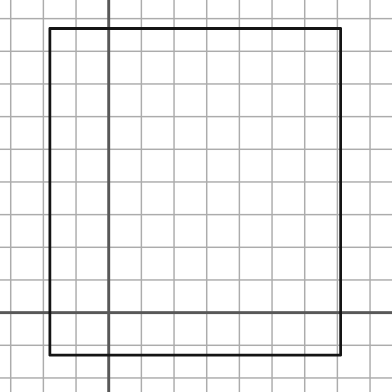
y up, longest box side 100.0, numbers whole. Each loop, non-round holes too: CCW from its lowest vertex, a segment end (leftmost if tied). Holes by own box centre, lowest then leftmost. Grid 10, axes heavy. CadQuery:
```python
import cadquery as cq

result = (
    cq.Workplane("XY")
    .moveTo(-18.0, -13.0)
    .lineTo(71.0, -13.0)
    .lineTo(71.0, 87.0)
    .lineTo(-18.0, 87.0)
    .close()
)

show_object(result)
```